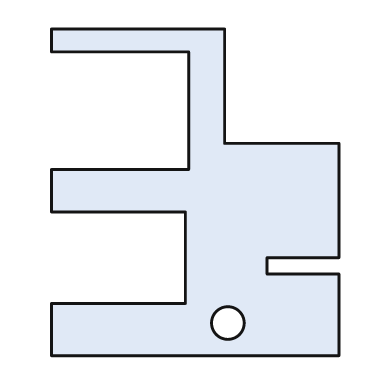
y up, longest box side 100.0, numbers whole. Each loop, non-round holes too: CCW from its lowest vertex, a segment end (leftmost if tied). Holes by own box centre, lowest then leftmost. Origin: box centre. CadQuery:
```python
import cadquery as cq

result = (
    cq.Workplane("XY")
    .moveTo(-44.0, -50.0)
    .lineTo(44.0, -50.0)
    .lineTo(44.0, -25.0)
    .lineTo(22.0, -25.0)
    .lineTo(22.0, -20.0)
    .lineTo(44.0, -20.0)
    .lineTo(44.0, 15.0)
    .lineTo(9.0, 15.0)
    .lineTo(9.0, 50.0)
    .lineTo(-44.0, 50.0)
    .lineTo(-44.0, 43.0)
    .lineTo(-2.0, 43.0)
    .lineTo(-2.0, 7.0)
    .lineTo(-44.0, 7.0)
    .lineTo(-44.0, -6.0)
    .lineTo(-3.0, -6.0)
    .lineTo(-3.0, -34.0)
    .lineTo(-44.0, -34.0)
    .close()
    .moveTo(10.0, -40.0)
    .circle(5.0)
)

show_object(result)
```